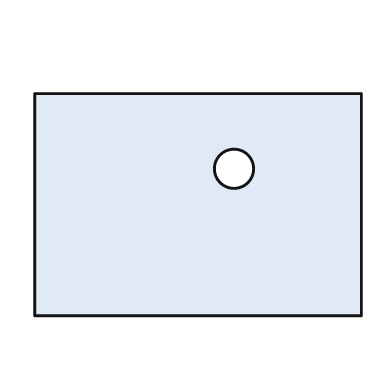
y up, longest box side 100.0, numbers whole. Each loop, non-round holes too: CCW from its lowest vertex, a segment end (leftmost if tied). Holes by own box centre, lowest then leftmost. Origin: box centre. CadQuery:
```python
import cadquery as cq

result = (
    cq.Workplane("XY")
    .moveTo(-50.0, -34.0)
    .lineTo(50.0, -34.0)
    .lineTo(50.0, 34.0)
    .lineTo(-50.0, 34.0)
    .close()
    .moveTo(11.0, 11.0)
    .circle(6.0)
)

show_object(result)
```